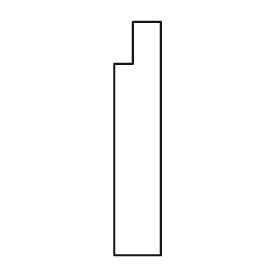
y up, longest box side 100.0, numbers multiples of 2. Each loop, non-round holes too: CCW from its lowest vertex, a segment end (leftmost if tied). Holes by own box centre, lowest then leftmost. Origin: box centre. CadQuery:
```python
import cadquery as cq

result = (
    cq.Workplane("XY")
    .moveTo(-10.0, -50.0)
    .lineTo(10.0, -50.0)
    .lineTo(10.0, 50.0)
    .lineTo(-2.0, 50.0)
    .lineTo(-2.0, 32.0)
    .lineTo(-10.0, 32.0)
    .close()
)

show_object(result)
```